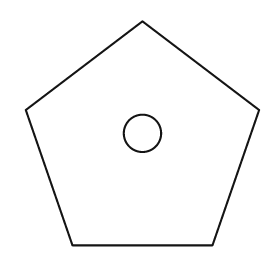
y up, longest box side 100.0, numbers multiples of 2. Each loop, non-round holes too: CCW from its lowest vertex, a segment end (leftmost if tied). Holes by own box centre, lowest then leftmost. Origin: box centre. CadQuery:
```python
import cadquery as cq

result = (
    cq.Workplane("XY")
    .moveTo(-30.0, -48.0)
    .lineTo(30.0, -48.0)
    .lineTo(50.0, 10.0)
    .lineTo(0.0, 48.0)
    .lineTo(-50.0, 10.0)
    .close()
    .moveTo(0.0, 0.0)
    .circle(8.0)
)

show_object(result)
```